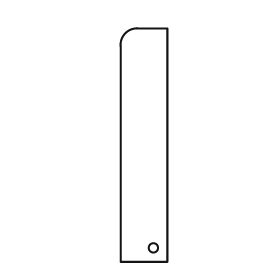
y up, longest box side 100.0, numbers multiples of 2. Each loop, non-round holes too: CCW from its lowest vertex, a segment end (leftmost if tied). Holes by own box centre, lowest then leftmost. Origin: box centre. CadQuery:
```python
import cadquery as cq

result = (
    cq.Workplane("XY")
    .moveTo(-10.0, -50.0)
    .lineTo(10.0, -50.0)
    .lineTo(10.0, 50.0)
    .lineTo(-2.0, 50.0)
    .threePointArc((-8.0, 48.0), (-10.0, 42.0))
    .close()
    .moveTo(4.0, -44.0)
    .circle(2.0)
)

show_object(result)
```